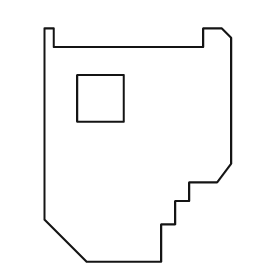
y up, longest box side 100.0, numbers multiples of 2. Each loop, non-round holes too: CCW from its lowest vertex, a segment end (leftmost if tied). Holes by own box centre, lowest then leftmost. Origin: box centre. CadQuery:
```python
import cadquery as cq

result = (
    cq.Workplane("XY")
    .moveTo(-22.0, -50.0)
    .lineTo(10.0, -50.0)
    .lineTo(10.0, -34.0)
    .lineTo(16.0, -34.0)
    .lineTo(16.0, -24.0)
    .lineTo(22.0, -24.0)
    .lineTo(22.0, -16.0)
    .lineTo(34.0, -16.0)
    .lineTo(40.0, -8.0)
    .lineTo(40.0, 46.0)
    .lineTo(36.0, 50.0)
    .lineTo(28.0, 50.0)
    .lineTo(28.0, 42.0)
    .lineTo(-36.0, 42.0)
    .lineTo(-36.0, 50.0)
    .lineTo(-40.0, 50.0)
    .lineTo(-40.0, -32.0)
    .close()
    .moveTo(-26.0, 10.0)
    .lineTo(-6.0, 10.0)
    .lineTo(-6.0, 30.0)
    .lineTo(-26.0, 30.0)
    .close()
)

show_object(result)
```